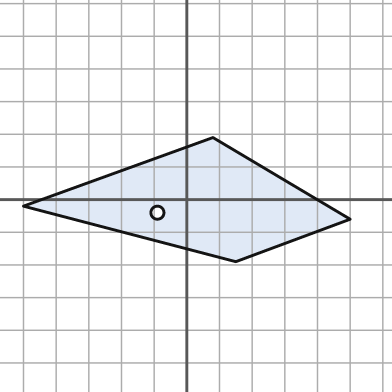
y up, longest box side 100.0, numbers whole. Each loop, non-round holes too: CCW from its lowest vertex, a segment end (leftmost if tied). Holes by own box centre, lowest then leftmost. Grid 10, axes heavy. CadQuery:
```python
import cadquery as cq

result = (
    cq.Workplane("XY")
    .moveTo(15.0, -19.0)
    .lineTo(50.0, -6.0)
    .lineTo(8.0, 19.0)
    .lineTo(-50.0, -2.0)
    .close()
    .moveTo(-9.0, -4.0)
    .circle(2.0)
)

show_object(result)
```